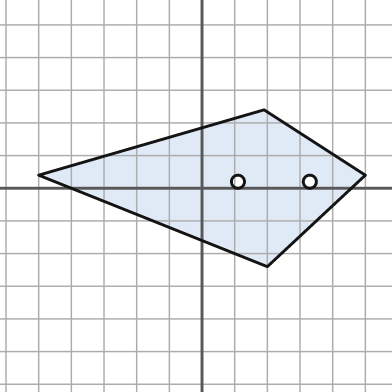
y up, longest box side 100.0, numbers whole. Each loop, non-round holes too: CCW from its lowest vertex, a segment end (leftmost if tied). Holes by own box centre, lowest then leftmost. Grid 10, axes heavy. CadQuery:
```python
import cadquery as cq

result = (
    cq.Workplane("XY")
    .moveTo(20.0, -24.0)
    .lineTo(50.0, 4.0)
    .lineTo(19.0, 24.0)
    .lineTo(-50.0, 4.0)
    .close()
    .moveTo(11.0, 2.0)
    .circle(2.0)
    .moveTo(33.0, 2.0)
    .circle(2.0)
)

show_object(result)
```